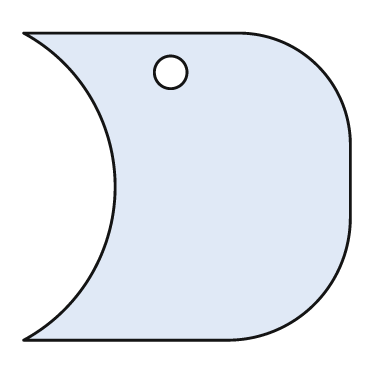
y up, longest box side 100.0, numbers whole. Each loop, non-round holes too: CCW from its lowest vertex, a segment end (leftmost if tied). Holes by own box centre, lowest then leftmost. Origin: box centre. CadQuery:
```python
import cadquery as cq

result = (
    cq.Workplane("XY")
    .moveTo(-50.0, -47.0)
    .lineTo(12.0, -47.0)
    .threePointArc((39.0, -36.0), (50.0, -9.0))
    .lineTo(50.0, 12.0)
    .threePointArc((40.0, 37.0), (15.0, 47.0))
    .lineTo(-50.0, 47.0)
    .threePointArc((-22.0, 0.0), (-50.0, -47.0))
    .close()
    .moveTo(-5.0, 35.0)
    .circle(5.0)
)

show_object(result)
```